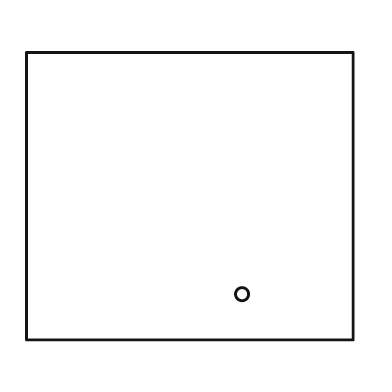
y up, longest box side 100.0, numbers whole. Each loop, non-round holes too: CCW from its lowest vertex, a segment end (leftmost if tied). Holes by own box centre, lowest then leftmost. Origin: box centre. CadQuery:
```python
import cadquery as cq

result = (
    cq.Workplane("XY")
    .moveTo(-50.0, -44.0)
    .lineTo(50.0, -44.0)
    .lineTo(50.0, 44.0)
    .lineTo(-50.0, 44.0)
    .close()
    .moveTo(16.0, -30.0)
    .circle(2.0)
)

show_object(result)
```